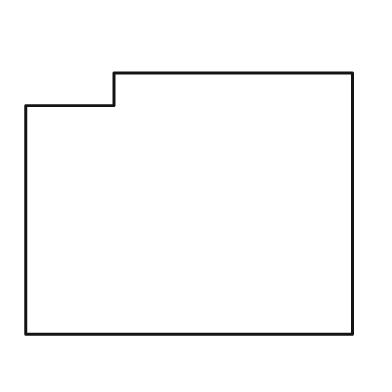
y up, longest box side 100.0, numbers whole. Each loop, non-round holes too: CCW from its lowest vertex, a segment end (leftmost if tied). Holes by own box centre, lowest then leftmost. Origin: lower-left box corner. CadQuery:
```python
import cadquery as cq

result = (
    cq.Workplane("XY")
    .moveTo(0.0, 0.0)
    .lineTo(100.0, 0.0)
    .lineTo(100.0, 80.0)
    .lineTo(27.0, 80.0)
    .lineTo(27.0, 70.0)
    .lineTo(0.0, 70.0)
    .close()
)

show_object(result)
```